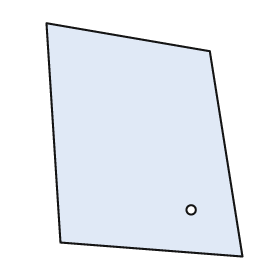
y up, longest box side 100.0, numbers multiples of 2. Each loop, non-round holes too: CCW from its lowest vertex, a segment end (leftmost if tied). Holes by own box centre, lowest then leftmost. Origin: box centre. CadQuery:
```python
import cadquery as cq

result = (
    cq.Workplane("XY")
    .moveTo(42.0, -50.0)
    .lineTo(28.0, 38.0)
    .lineTo(-42.0, 50.0)
    .lineTo(-36.0, -44.0)
    .close()
    .moveTo(20.0, -30.0)
    .circle(2.0)
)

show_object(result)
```